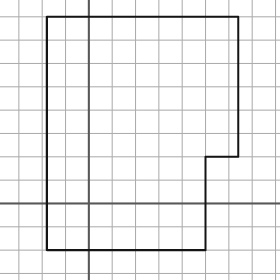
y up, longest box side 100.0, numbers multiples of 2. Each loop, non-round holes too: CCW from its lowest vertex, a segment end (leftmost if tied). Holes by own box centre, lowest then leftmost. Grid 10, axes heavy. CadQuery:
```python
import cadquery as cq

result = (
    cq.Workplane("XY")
    .moveTo(-18.0, -20.0)
    .lineTo(50.0, -20.0)
    .lineTo(50.0, 20.0)
    .lineTo(64.0, 20.0)
    .lineTo(64.0, 80.0)
    .lineTo(-18.0, 80.0)
    .close()
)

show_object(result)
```